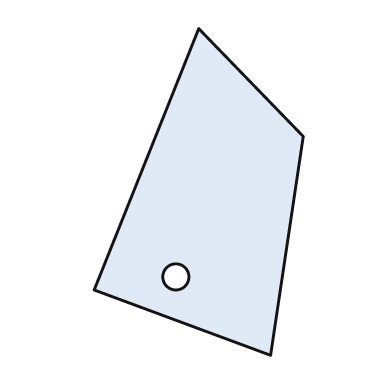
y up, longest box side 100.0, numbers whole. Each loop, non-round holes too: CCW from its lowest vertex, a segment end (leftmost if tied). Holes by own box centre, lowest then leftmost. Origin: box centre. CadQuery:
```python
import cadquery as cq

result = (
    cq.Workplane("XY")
    .moveTo(22.0, -50.0)
    .lineTo(32.0, 17.0)
    .lineTo(0.0, 50.0)
    .lineTo(-32.0, -30.0)
    .close()
    .moveTo(-7.0, -26.0)
    .circle(4.0)
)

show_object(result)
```